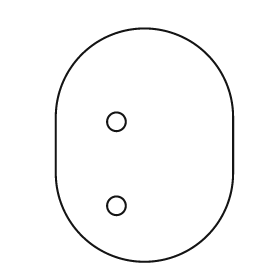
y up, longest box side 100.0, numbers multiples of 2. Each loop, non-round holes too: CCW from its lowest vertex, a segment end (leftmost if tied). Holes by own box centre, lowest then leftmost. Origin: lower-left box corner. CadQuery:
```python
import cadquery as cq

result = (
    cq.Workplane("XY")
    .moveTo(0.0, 38.0)
    .threePointArc((38.0, 0.0), (76.0, 38.0))
    .lineTo(76.0, 62.0)
    .threePointArc((38.0, 100.0), (0.0, 62.0))
    .close()
    .moveTo(26.0, 24.0)
    .circle(4.0)
    .moveTo(26.0, 60.0)
    .circle(4.0)
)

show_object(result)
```